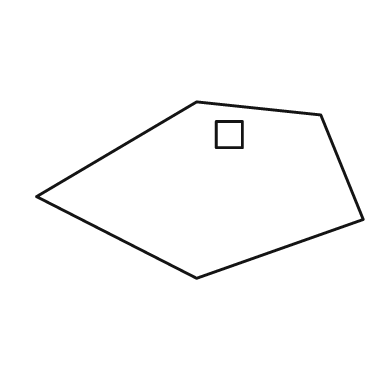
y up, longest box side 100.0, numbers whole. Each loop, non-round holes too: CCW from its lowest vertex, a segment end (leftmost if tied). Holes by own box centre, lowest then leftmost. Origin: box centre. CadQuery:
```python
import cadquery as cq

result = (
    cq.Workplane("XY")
    .moveTo(-1.0, -27.0)
    .lineTo(50.0, -9.0)
    .lineTo(37.0, 23.0)
    .lineTo(-1.0, 27.0)
    .lineTo(-50.0, -2.0)
    .close()
    .moveTo(5.0, 13.0)
    .lineTo(13.0, 13.0)
    .lineTo(13.0, 21.0)
    .lineTo(5.0, 21.0)
    .close()
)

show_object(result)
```